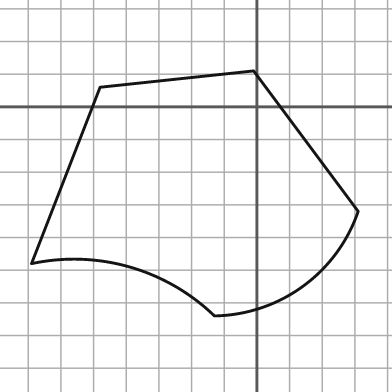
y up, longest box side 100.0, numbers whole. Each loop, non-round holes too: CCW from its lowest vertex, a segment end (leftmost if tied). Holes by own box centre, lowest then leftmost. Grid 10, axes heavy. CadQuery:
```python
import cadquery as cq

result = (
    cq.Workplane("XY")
    .moveTo(-13.0, -64.0)
    .threePointArc((14.0, -55.0), (31.0, -32.0))
    .lineTo(-1.0, 11.0)
    .lineTo(-48.0, 6.0)
    .lineTo(-69.0, -48.0)
    .threePointArc((-39.0, -49.0), (-13.0, -64.0))
    .close()
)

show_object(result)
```